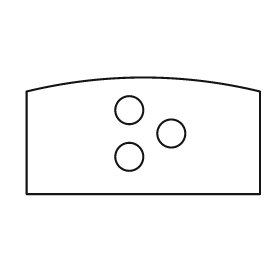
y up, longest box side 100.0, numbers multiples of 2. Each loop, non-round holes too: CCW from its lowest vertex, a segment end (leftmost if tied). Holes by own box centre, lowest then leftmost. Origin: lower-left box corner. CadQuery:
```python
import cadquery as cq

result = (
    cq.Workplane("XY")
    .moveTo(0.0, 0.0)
    .lineTo(100.0, 0.0)
    .lineTo(100.0, 44.0)
    .threePointArc((50.0, 50.0), (0.0, 44.0))
    .close()
    .moveTo(44.0, 16.0)
    .circle(6.0)
    .moveTo(62.0, 26.0)
    .circle(6.0)
    .moveTo(44.0, 36.0)
    .circle(6.0)
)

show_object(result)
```